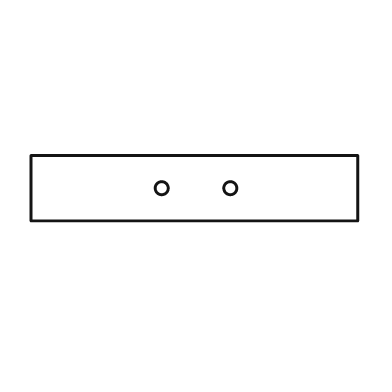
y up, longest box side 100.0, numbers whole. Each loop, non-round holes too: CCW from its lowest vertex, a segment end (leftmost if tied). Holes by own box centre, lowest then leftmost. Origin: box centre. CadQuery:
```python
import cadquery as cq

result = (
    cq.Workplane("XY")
    .moveTo(-50.0, -10.0)
    .lineTo(50.0, -10.0)
    .lineTo(50.0, 10.0)
    .lineTo(-50.0, 10.0)
    .close()
    .moveTo(-10.0, 0.0)
    .circle(2.0)
    .moveTo(11.0, 0.0)
    .circle(2.0)
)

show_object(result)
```